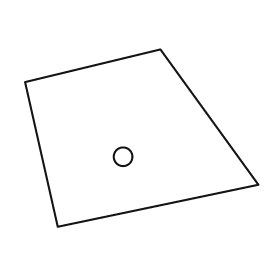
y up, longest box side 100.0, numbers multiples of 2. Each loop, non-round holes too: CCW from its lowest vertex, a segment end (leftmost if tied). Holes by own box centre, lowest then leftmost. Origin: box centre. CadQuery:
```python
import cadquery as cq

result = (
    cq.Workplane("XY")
    .moveTo(-36.0, -38.0)
    .lineTo(50.0, -20.0)
    .lineTo(8.0, 38.0)
    .lineTo(-50.0, 24.0)
    .close()
    .moveTo(-8.0, -8.0)
    .circle(4.0)
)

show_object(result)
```